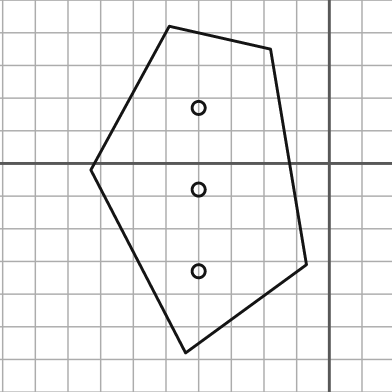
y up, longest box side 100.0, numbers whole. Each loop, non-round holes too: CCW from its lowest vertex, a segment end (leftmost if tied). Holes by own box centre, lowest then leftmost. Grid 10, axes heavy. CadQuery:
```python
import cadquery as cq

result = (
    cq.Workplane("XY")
    .moveTo(-44.0, -58.0)
    .lineTo(-7.0, -31.0)
    .lineTo(-18.0, 35.0)
    .lineTo(-49.0, 42.0)
    .lineTo(-73.0, -2.0)
    .close()
    .moveTo(-40.0, -33.0)
    .circle(2.0)
    .moveTo(-40.0, -8.0)
    .circle(2.0)
    .moveTo(-40.0, 17.0)
    .circle(2.0)
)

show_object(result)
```